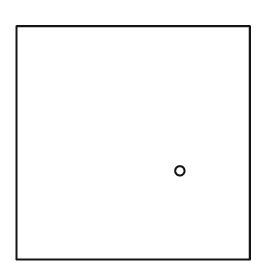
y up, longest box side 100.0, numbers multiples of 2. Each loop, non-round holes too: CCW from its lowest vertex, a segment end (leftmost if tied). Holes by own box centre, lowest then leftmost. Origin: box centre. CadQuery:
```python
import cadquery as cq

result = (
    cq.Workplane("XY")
    .moveTo(-50.0, -50.0)
    .lineTo(50.0, -50.0)
    .lineTo(50.0, 50.0)
    .lineTo(-50.0, 50.0)
    .close()
    .moveTo(20.0, -12.0)
    .circle(2.0)
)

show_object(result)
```